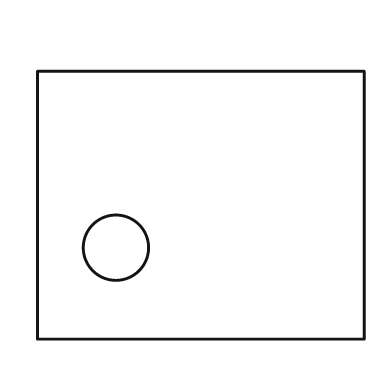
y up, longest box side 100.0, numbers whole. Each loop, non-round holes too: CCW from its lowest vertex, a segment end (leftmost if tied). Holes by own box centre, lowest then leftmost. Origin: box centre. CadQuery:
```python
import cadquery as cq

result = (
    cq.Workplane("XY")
    .moveTo(-50.0, -41.0)
    .lineTo(50.0, -41.0)
    .lineTo(50.0, 41.0)
    .lineTo(-50.0, 41.0)
    .close()
    .moveTo(-26.0, -13.0)
    .circle(10.0)
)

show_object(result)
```